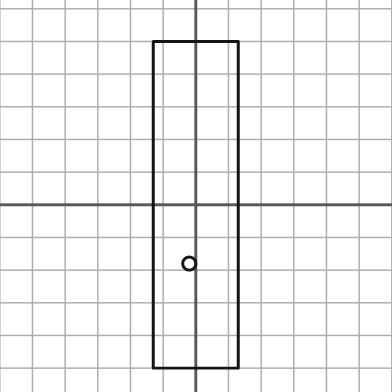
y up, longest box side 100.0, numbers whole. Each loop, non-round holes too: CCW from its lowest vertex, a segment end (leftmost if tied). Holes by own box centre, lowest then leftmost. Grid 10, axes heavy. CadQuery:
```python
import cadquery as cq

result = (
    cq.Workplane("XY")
    .moveTo(-13.0, -50.0)
    .lineTo(13.0, -50.0)
    .lineTo(13.0, 50.0)
    .lineTo(-13.0, 50.0)
    .close()
    .moveTo(-2.0, -18.0)
    .circle(2.0)
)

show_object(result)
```